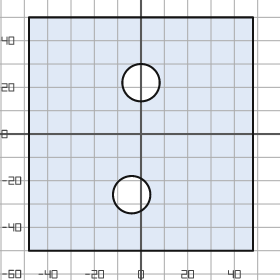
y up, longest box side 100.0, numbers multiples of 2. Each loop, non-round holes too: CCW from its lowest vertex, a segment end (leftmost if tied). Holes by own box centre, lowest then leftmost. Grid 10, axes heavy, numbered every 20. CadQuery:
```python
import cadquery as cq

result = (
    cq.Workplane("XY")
    .moveTo(-48.0, -50.0)
    .lineTo(48.0, -50.0)
    .lineTo(48.0, 50.0)
    .lineTo(-48.0, 50.0)
    .close()
    .moveTo(-4.0, -26.0)
    .circle(8.0)
    .moveTo(0.0, 22.0)
    .circle(8.0)
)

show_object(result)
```